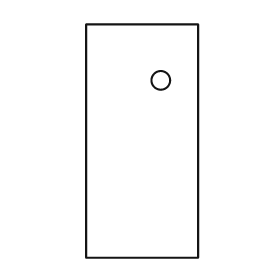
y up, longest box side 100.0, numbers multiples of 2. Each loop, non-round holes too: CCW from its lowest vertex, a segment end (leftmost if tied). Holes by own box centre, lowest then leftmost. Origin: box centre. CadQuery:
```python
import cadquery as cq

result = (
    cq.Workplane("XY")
    .moveTo(-24.0, -50.0)
    .lineTo(24.0, -50.0)
    .lineTo(24.0, 50.0)
    .lineTo(-24.0, 50.0)
    .close()
    .moveTo(8.0, 26.0)
    .circle(4.0)
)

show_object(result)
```